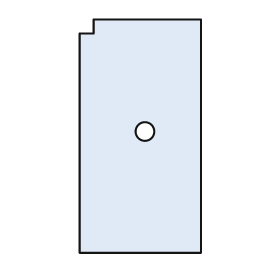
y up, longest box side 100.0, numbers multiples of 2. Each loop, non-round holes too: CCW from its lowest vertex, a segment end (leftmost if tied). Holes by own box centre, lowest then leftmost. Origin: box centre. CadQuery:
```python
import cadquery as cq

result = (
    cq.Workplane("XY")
    .moveTo(-26.0, -50.0)
    .lineTo(26.0, -50.0)
    .lineTo(26.0, 50.0)
    .lineTo(-20.0, 50.0)
    .lineTo(-20.0, 44.0)
    .lineTo(-26.0, 44.0)
    .close()
    .moveTo(2.0, 2.0)
    .circle(4.0)
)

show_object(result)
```